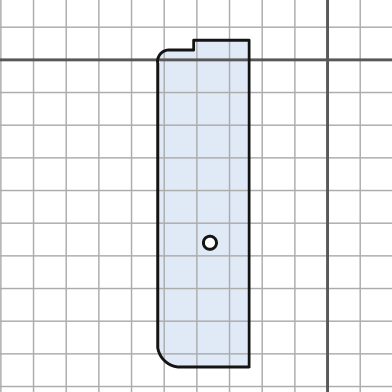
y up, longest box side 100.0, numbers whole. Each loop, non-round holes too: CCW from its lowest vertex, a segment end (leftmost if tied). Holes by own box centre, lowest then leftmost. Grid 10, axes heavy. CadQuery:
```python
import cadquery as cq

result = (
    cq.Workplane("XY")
    .moveTo(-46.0, -94.0)
    .lineTo(-24.0, -94.0)
    .lineTo(-24.0, 6.0)
    .lineTo(-41.0, 6.0)
    .lineTo(-41.0, 3.0)
    .lineTo(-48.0, 3.0)
    .threePointArc((-51.0, 2.0), (-52.0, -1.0))
    .lineTo(-52.0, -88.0)
    .threePointArc((-50.0, -92.0), (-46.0, -94.0))
    .close()
    .moveTo(-36.0, -56.0)
    .circle(2.0)
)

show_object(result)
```